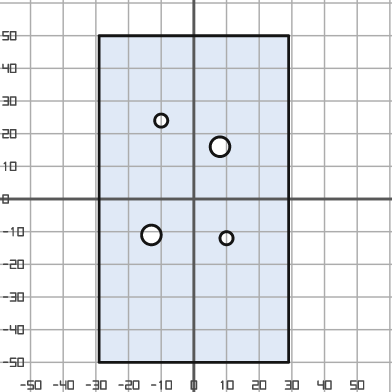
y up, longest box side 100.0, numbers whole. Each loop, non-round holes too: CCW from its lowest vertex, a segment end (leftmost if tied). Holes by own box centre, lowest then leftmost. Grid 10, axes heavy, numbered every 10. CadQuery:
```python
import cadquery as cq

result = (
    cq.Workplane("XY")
    .moveTo(-29.0, -50.0)
    .lineTo(29.0, -50.0)
    .lineTo(29.0, 50.0)
    .lineTo(-29.0, 50.0)
    .close()
    .moveTo(10.0, -12.0)
    .circle(2.0)
    .moveTo(-13.0, -11.0)
    .circle(3.0)
    .moveTo(8.0, 16.0)
    .circle(3.0)
    .moveTo(-10.0, 24.0)
    .circle(2.0)
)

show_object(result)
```